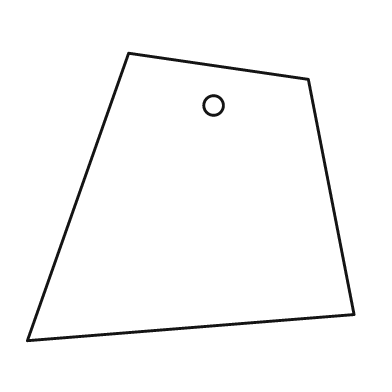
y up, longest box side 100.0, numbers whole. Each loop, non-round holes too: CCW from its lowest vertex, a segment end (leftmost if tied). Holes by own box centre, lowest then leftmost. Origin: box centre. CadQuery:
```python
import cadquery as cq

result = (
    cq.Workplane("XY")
    .moveTo(-50.0, -44.0)
    .lineTo(50.0, -36.0)
    .lineTo(36.0, 36.0)
    .lineTo(-19.0, 44.0)
    .close()
    .moveTo(7.0, 28.0)
    .circle(3.0)
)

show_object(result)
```